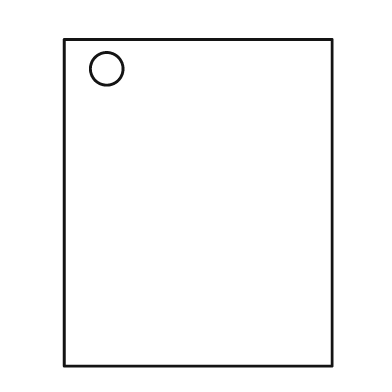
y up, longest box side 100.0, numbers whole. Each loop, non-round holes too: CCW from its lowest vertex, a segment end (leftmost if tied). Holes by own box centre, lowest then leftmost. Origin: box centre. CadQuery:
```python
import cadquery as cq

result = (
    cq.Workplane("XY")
    .moveTo(-41.0, -50.0)
    .lineTo(41.0, -50.0)
    .lineTo(41.0, 50.0)
    .lineTo(-41.0, 50.0)
    .close()
    .moveTo(-28.0, 41.0)
    .circle(5.0)
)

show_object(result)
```